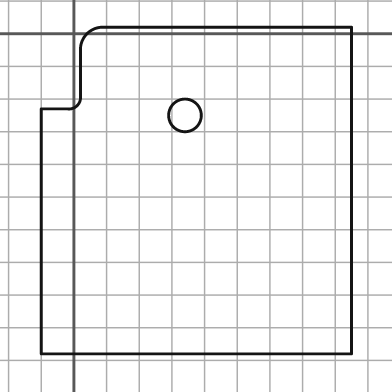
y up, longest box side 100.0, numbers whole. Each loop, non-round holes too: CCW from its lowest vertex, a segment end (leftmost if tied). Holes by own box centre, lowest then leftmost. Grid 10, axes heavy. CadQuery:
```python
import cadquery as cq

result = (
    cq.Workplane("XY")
    .moveTo(-10.0, -98.0)
    .lineTo(85.0, -98.0)
    .lineTo(85.0, 2.0)
    .lineTo(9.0, 2.0)
    .threePointArc((4.0, 0.0), (2.0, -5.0))
    .lineTo(2.0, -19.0)
    .threePointArc((1.0, -22.0), (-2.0, -23.0))
    .lineTo(-10.0, -23.0)
    .close()
    .moveTo(34.0, -25.0)
    .circle(5.0)
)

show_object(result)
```